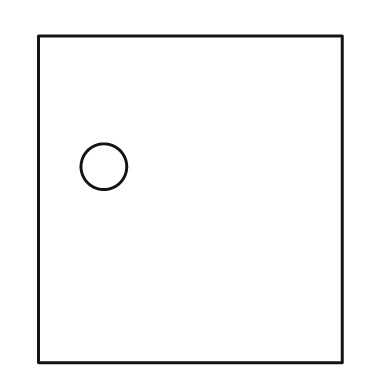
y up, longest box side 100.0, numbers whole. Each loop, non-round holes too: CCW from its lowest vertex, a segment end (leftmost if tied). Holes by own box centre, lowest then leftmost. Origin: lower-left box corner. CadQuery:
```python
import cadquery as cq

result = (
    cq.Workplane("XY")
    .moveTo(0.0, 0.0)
    .lineTo(93.0, 0.0)
    .lineTo(93.0, 100.0)
    .lineTo(0.0, 100.0)
    .close()
    .moveTo(20.0, 60.0)
    .circle(7.0)
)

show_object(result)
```